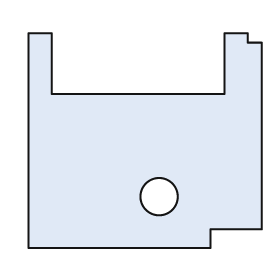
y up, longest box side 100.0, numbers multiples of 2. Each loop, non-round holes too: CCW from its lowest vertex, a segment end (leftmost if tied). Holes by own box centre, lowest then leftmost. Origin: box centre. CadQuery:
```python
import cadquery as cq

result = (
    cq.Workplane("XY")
    .moveTo(-50.0, -46.0)
    .lineTo(28.0, -46.0)
    .lineTo(28.0, -38.0)
    .lineTo(50.0, -38.0)
    .lineTo(50.0, 42.0)
    .lineTo(44.0, 42.0)
    .lineTo(44.0, 46.0)
    .lineTo(34.0, 46.0)
    .lineTo(34.0, 20.0)
    .lineTo(-40.0, 20.0)
    .lineTo(-40.0, 46.0)
    .lineTo(-50.0, 46.0)
    .close()
    .moveTo(6.0, -24.0)
    .circle(8.0)
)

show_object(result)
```